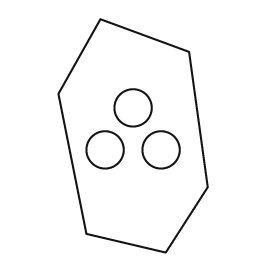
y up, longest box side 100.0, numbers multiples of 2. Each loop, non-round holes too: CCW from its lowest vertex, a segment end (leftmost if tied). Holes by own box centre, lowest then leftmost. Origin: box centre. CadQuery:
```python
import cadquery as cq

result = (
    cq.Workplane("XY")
    .moveTo(14.0, -50.0)
    .lineTo(32.0, -22.0)
    .lineTo(24.0, 36.0)
    .lineTo(-14.0, 50.0)
    .lineTo(-32.0, 18.0)
    .lineTo(-20.0, -42.0)
    .close()
    .moveTo(-12.0, -6.0)
    .circle(8.0)
    .moveTo(12.0, -6.0)
    .circle(8.0)
    .moveTo(0.0, 12.0)
    .circle(8.0)
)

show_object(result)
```